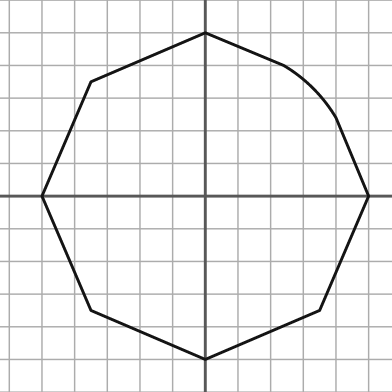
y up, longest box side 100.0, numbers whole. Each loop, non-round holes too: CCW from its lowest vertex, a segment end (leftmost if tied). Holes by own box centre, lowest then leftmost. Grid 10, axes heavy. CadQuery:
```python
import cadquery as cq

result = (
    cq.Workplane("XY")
    .moveTo(0.0, -50.0)
    .lineTo(35.0, -35.0)
    .lineTo(50.0, 0.0)
    .lineTo(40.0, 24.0)
    .threePointArc((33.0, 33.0), (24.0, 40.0))
    .lineTo(0.0, 50.0)
    .lineTo(-35.0, 35.0)
    .lineTo(-50.0, 0.0)
    .lineTo(-35.0, -35.0)
    .close()
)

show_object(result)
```